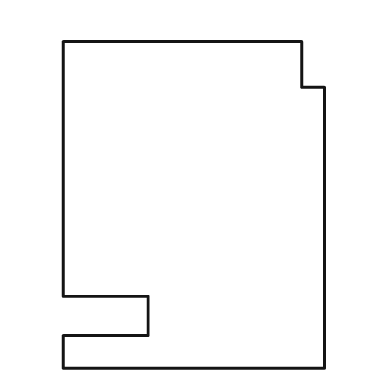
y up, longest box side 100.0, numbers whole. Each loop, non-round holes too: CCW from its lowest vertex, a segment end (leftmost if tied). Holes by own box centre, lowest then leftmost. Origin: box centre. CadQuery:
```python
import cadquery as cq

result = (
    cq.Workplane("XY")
    .moveTo(-40.0, -50.0)
    .lineTo(40.0, -50.0)
    .lineTo(40.0, 36.0)
    .lineTo(33.0, 36.0)
    .lineTo(33.0, 50.0)
    .lineTo(-40.0, 50.0)
    .lineTo(-40.0, -28.0)
    .lineTo(-14.0, -28.0)
    .lineTo(-14.0, -40.0)
    .lineTo(-40.0, -40.0)
    .close()
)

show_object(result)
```